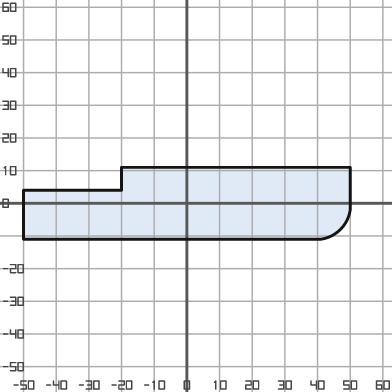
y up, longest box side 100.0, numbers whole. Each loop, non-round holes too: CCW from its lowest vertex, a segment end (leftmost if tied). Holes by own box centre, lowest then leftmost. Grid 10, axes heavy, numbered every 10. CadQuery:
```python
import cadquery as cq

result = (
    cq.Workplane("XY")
    .moveTo(-50.0, -11.0)
    .lineTo(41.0, -11.0)
    .threePointArc((47.0, -8.0), (50.0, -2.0))
    .lineTo(50.0, 11.0)
    .lineTo(-20.0, 11.0)
    .lineTo(-20.0, 4.0)
    .lineTo(-50.0, 4.0)
    .close()
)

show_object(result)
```